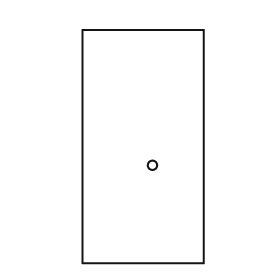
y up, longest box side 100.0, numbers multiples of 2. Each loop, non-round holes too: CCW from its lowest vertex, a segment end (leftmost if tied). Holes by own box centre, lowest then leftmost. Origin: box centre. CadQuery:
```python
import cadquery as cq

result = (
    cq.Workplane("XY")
    .moveTo(-26.0, -50.0)
    .lineTo(26.0, -50.0)
    .lineTo(26.0, 50.0)
    .lineTo(-26.0, 50.0)
    .close()
    .moveTo(4.0, -8.0)
    .circle(2.0)
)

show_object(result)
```